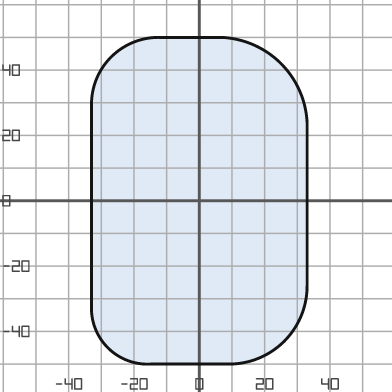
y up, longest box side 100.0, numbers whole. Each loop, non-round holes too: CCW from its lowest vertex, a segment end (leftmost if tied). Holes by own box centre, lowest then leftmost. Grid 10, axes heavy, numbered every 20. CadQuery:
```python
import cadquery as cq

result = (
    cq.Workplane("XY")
    .moveTo(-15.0, -50.0)
    .lineTo(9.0, -50.0)
    .threePointArc((26.0, -43.0), (33.0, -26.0))
    .lineTo(33.0, 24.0)
    .threePointArc((25.0, 42.0), (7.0, 50.0))
    .lineTo(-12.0, 50.0)
    .threePointArc((-27.0, 44.0), (-33.0, 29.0))
    .lineTo(-33.0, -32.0)
    .threePointArc((-28.0, -45.0), (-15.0, -50.0))
    .close()
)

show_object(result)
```